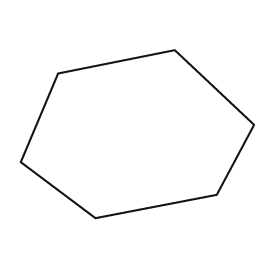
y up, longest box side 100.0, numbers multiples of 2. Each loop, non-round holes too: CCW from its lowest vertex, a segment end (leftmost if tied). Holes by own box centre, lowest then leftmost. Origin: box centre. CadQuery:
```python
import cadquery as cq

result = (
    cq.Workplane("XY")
    .moveTo(-18.0, -36.0)
    .lineTo(34.0, -26.0)
    .lineTo(50.0, 4.0)
    .lineTo(16.0, 36.0)
    .lineTo(-34.0, 26.0)
    .lineTo(-50.0, -12.0)
    .close()
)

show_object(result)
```